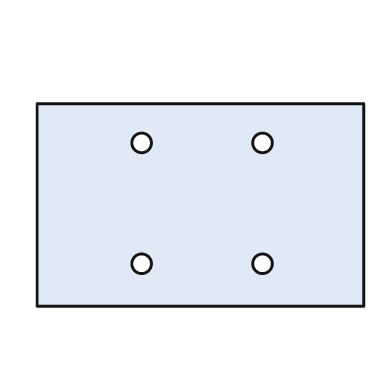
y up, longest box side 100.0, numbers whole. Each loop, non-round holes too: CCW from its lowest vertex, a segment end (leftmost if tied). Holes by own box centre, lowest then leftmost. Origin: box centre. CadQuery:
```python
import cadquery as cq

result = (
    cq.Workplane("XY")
    .moveTo(-50.0, -31.0)
    .lineTo(50.0, -31.0)
    .lineTo(50.0, 31.0)
    .lineTo(-50.0, 31.0)
    .close()
    .moveTo(-18.0, -18.0)
    .circle(3.0)
    .moveTo(19.0, -18.0)
    .circle(3.0)
    .moveTo(-18.0, 19.0)
    .circle(3.0)
    .moveTo(19.0, 19.0)
    .circle(3.0)
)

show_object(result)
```